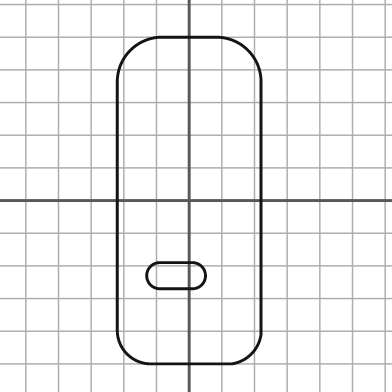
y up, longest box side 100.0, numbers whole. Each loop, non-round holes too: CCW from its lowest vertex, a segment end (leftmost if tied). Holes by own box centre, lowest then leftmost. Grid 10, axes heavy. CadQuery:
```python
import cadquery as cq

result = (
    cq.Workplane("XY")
    .moveTo(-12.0, -50.0)
    .lineTo(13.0, -50.0)
    .threePointArc((19.0, -47.0), (22.0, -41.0))
    .lineTo(22.0, 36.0)
    .threePointArc((18.0, 46.0), (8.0, 50.0))
    .lineTo(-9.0, 50.0)
    .threePointArc((-18.0, 46.0), (-22.0, 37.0))
    .lineTo(-22.0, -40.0)
    .threePointArc((-19.0, -47.0), (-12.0, -50.0))
    .close()
    .moveTo(-9.0, -27.0)
    .lineTo(1.0, -27.0)
    .threePointArc((5.0, -23.0), (1.0, -19.0))
    .lineTo(-9.0, -19.0)
    .threePointArc((-13.0, -23.0), (-9.0, -27.0))
    .close()
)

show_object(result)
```